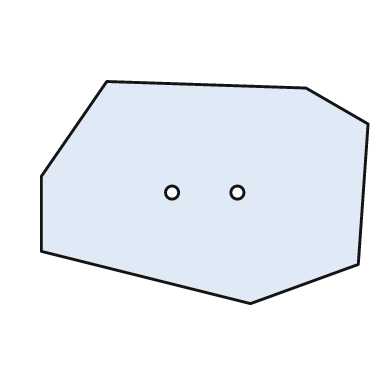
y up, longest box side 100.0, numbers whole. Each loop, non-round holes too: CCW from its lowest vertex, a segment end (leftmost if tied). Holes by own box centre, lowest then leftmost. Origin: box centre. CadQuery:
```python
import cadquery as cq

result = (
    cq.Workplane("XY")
    .moveTo(14.0, -34.0)
    .lineTo(47.0, -22.0)
    .lineTo(50.0, 21.0)
    .lineTo(31.0, 32.0)
    .lineTo(-30.0, 34.0)
    .lineTo(-50.0, 5.0)
    .lineTo(-50.0, -18.0)
    .close()
    .moveTo(-10.0, 0.0)
    .circle(2.0)
    .moveTo(10.0, 0.0)
    .circle(2.0)
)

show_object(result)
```